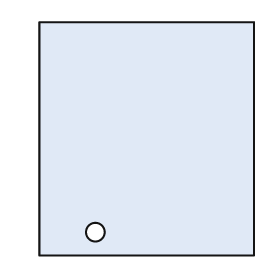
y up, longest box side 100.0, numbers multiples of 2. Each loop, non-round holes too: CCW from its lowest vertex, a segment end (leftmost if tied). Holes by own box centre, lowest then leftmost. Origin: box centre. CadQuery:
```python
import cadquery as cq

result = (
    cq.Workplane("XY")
    .moveTo(-46.0, -50.0)
    .lineTo(46.0, -50.0)
    .lineTo(46.0, 50.0)
    .lineTo(-46.0, 50.0)
    .close()
    .moveTo(-22.0, -40.0)
    .circle(4.0)
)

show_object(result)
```